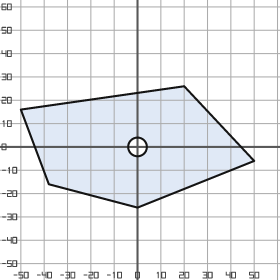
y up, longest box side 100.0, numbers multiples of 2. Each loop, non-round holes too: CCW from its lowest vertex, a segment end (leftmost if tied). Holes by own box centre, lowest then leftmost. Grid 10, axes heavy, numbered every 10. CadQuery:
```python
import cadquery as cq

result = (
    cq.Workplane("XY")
    .moveTo(0.0, -26.0)
    .lineTo(50.0, -6.0)
    .lineTo(20.0, 26.0)
    .lineTo(-50.0, 16.0)
    .lineTo(-38.0, -16.0)
    .close()
    .moveTo(0.0, 0.0)
    .circle(4.0)
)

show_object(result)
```